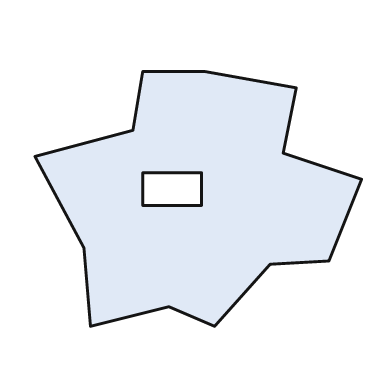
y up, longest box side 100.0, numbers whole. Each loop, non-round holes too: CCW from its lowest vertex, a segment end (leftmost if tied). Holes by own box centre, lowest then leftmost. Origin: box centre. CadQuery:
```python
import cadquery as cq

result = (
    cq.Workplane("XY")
    .moveTo(-33.0, -39.0)
    .lineTo(-9.0, -33.0)
    .lineTo(5.0, -39.0)
    .lineTo(22.0, -20.0)
    .lineTo(40.0, -19.0)
    .lineTo(50.0, 6.0)
    .lineTo(26.0, 14.0)
    .lineTo(30.0, 34.0)
    .lineTo(2.0, 39.0)
    .lineTo(-17.0, 39.0)
    .lineTo(-20.0, 21.0)
    .lineTo(-50.0, 13.0)
    .lineTo(-35.0, -15.0)
    .close()
    .moveTo(-17.0, -2.0)
    .lineTo(1.0, -2.0)
    .lineTo(1.0, 8.0)
    .lineTo(-17.0, 8.0)
    .close()
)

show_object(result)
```